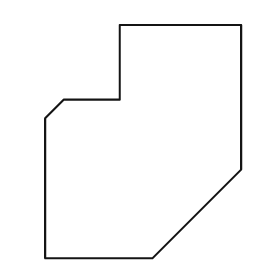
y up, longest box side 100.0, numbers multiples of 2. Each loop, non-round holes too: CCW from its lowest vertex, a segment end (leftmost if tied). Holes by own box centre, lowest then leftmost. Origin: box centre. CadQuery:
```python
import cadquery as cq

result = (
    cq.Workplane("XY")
    .moveTo(-42.0, -50.0)
    .lineTo(4.0, -50.0)
    .lineTo(42.0, -12.0)
    .lineTo(42.0, 50.0)
    .lineTo(-10.0, 50.0)
    .lineTo(-10.0, 18.0)
    .lineTo(-34.0, 18.0)
    .lineTo(-42.0, 10.0)
    .close()
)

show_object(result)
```